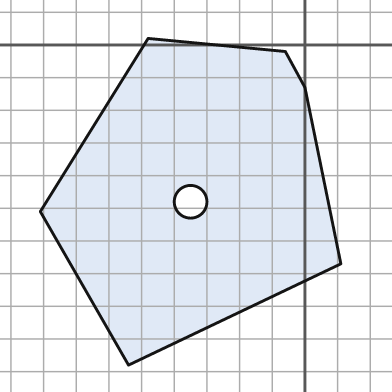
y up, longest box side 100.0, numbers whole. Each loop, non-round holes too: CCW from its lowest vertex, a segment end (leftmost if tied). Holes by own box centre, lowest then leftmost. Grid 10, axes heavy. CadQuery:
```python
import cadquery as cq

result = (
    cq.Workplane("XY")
    .moveTo(-54.0, -98.0)
    .lineTo(11.0, -67.0)
    .lineTo(0.0, -13.0)
    .lineTo(-6.0, -2.0)
    .lineTo(-48.0, 2.0)
    .lineTo(-81.0, -51.0)
    .close()
    .moveTo(-35.0, -48.0)
    .circle(5.0)
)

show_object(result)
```